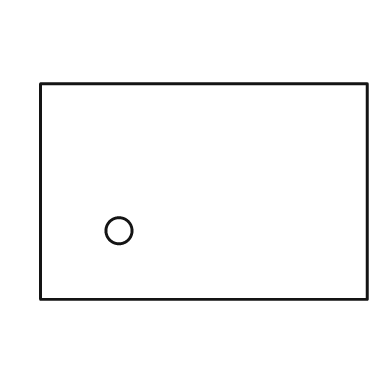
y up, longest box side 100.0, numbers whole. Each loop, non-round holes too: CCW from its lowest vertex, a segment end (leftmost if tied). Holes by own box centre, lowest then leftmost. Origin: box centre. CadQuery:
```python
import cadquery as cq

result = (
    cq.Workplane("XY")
    .moveTo(-50.0, -33.0)
    .lineTo(50.0, -33.0)
    .lineTo(50.0, 33.0)
    .lineTo(-50.0, 33.0)
    .close()
    .moveTo(-26.0, -12.0)
    .circle(4.0)
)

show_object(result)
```